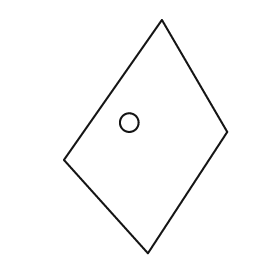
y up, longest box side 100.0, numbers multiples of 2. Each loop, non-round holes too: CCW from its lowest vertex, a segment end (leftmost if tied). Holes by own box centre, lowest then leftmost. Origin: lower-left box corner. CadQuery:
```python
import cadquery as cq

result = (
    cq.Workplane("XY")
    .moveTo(36.0, 0.0)
    .lineTo(70.0, 52.0)
    .lineTo(42.0, 100.0)
    .lineTo(0.0, 40.0)
    .close()
    .moveTo(28.0, 56.0)
    .circle(4.0)
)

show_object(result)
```